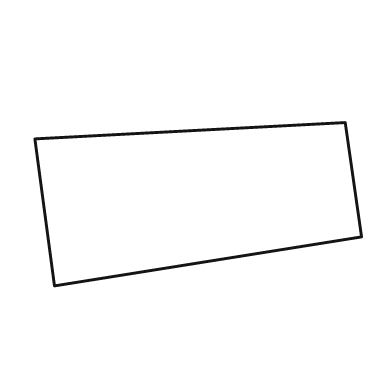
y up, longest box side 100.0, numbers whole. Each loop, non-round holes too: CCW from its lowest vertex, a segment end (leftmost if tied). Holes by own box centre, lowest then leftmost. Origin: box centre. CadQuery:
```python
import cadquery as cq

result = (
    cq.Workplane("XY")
    .moveTo(-44.0, -25.0)
    .lineTo(50.0, -10.0)
    .lineTo(45.0, 25.0)
    .lineTo(-50.0, 20.0)
    .close()
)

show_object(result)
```